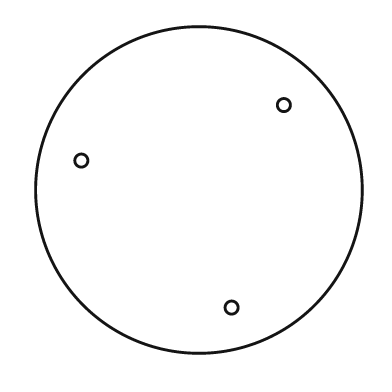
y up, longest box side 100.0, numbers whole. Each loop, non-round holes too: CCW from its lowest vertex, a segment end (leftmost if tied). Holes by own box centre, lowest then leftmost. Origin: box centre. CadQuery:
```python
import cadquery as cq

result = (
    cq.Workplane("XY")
    .moveTo(0.0, 0.0)
    .circle(50.0)
    .moveTo(10.0, -36.0)
    .circle(2.0)
    .moveTo(-36.0, 9.0)
    .circle(2.0)
    .moveTo(26.0, 26.0)
    .circle(2.0)
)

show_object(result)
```